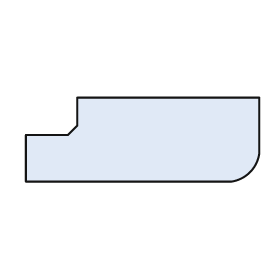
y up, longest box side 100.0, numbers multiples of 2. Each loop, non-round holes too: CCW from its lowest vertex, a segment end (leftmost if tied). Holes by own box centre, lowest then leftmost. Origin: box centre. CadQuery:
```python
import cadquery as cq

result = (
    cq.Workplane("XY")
    .moveTo(-50.0, -18.0)
    .lineTo(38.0, -18.0)
    .threePointArc((46.0, -14.0), (50.0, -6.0))
    .lineTo(50.0, 18.0)
    .lineTo(-28.0, 18.0)
    .lineTo(-28.0, 6.0)
    .lineTo(-32.0, 2.0)
    .lineTo(-50.0, 2.0)
    .close()
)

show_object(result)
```